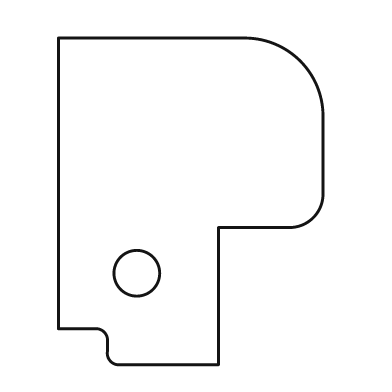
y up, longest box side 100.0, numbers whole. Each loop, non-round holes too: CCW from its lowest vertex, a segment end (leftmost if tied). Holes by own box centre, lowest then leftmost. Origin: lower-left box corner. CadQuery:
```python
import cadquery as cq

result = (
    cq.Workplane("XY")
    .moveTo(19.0, 0.0)
    .lineTo(49.0, 0.0)
    .lineTo(49.0, 42.0)
    .lineTo(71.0, 42.0)
    .threePointArc((78.0, 45.0), (81.0, 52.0))
    .lineTo(81.0, 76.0)
    .threePointArc((74.0, 93.0), (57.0, 100.0))
    .lineTo(0.0, 100.0)
    .lineTo(0.0, 11.0)
    .lineTo(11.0, 11.0)
    .threePointArc((14.0, 10.0), (15.0, 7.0))
    .lineTo(15.0, 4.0)
    .threePointArc((16.0, 1.0), (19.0, 0.0))
    .close()
    .moveTo(24.0, 28.0)
    .circle(7.0)
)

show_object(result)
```